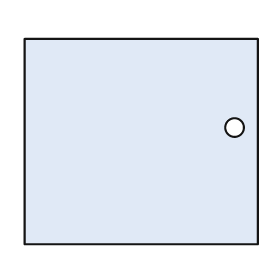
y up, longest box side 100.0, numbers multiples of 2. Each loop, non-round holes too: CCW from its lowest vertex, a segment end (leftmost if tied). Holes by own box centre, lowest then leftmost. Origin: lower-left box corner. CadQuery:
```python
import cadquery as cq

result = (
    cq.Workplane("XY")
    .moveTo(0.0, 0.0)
    .lineTo(100.0, 0.0)
    .lineTo(100.0, 88.0)
    .lineTo(0.0, 88.0)
    .close()
    .moveTo(90.0, 50.0)
    .circle(4.0)
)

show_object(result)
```